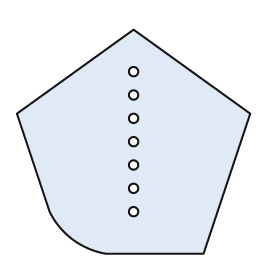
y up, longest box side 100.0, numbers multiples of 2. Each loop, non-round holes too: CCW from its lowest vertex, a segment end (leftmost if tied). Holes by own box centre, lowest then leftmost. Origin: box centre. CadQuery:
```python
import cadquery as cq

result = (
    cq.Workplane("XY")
    .moveTo(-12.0, -48.0)
    .lineTo(30.0, -48.0)
    .lineTo(50.0, 12.0)
    .lineTo(0.0, 48.0)
    .lineTo(-50.0, 12.0)
    .lineTo(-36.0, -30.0)
    .threePointArc((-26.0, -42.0), (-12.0, -48.0))
    .close()
    .moveTo(0.0, -30.0)
    .circle(2.0)
    .moveTo(0.0, -20.0)
    .circle(2.0)
    .moveTo(0.0, -10.0)
    .circle(2.0)
    .moveTo(0.0, 0.0)
    .circle(2.0)
    .moveTo(0.0, 10.0)
    .circle(2.0)
    .moveTo(0.0, 20.0)
    .circle(2.0)
    .moveTo(0.0, 30.0)
    .circle(2.0)
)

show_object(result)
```